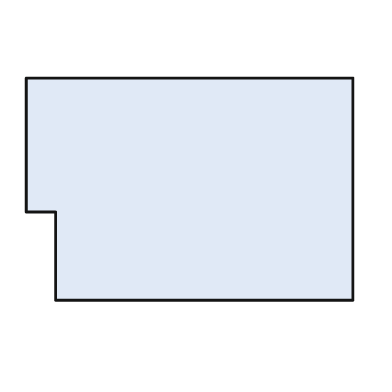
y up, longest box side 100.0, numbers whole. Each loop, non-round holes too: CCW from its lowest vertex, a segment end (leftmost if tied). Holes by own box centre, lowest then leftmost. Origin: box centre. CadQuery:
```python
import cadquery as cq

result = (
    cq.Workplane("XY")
    .moveTo(-41.0, -34.0)
    .lineTo(50.0, -34.0)
    .lineTo(50.0, 34.0)
    .lineTo(-50.0, 34.0)
    .lineTo(-50.0, -7.0)
    .lineTo(-41.0, -7.0)
    .close()
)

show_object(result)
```